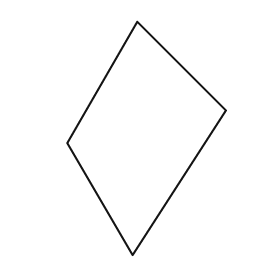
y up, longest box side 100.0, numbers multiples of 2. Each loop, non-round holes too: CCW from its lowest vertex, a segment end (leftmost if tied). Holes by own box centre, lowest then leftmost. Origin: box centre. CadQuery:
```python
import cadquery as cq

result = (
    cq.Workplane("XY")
    .moveTo(-6.0, -50.0)
    .lineTo(34.0, 12.0)
    .lineTo(-4.0, 50.0)
    .lineTo(-34.0, -2.0)
    .close()
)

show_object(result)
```